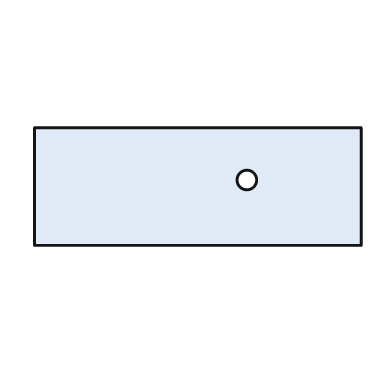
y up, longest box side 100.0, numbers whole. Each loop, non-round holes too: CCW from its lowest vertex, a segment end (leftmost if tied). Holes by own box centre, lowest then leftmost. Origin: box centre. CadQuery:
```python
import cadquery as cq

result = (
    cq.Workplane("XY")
    .moveTo(-50.0, -18.0)
    .lineTo(50.0, -18.0)
    .lineTo(50.0, 18.0)
    .lineTo(-50.0, 18.0)
    .close()
    .moveTo(15.0, 2.0)
    .circle(3.0)
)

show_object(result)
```